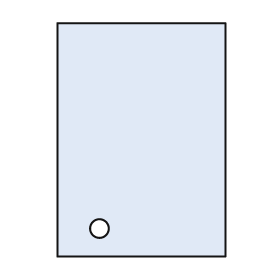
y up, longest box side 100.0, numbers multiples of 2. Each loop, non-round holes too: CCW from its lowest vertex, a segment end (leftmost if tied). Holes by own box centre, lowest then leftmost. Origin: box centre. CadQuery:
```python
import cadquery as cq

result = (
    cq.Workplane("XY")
    .moveTo(-36.0, -50.0)
    .lineTo(36.0, -50.0)
    .lineTo(36.0, 50.0)
    .lineTo(-36.0, 50.0)
    .close()
    .moveTo(-18.0, -38.0)
    .circle(4.0)
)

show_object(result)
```